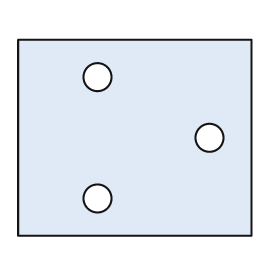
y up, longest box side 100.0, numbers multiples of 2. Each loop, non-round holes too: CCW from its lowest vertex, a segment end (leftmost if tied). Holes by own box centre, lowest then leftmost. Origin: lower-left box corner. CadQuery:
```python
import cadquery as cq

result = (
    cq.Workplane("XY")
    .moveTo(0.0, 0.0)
    .lineTo(100.0, 0.0)
    .lineTo(100.0, 84.0)
    .lineTo(0.0, 84.0)
    .close()
    .moveTo(34.0, 16.0)
    .circle(6.0)
    .moveTo(82.0, 42.0)
    .circle(6.0)
    .moveTo(34.0, 68.0)
    .circle(6.0)
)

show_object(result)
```